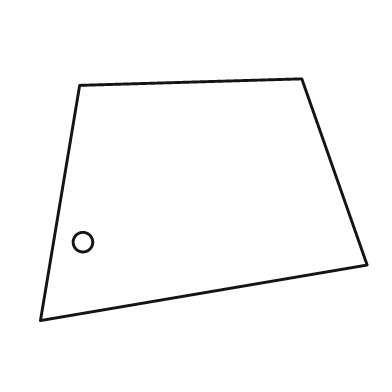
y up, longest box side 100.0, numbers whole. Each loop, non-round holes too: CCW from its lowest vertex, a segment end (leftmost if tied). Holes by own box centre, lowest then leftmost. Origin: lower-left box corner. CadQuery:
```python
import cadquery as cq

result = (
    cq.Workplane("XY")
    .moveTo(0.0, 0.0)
    .lineTo(100.0, 17.0)
    .lineTo(80.0, 74.0)
    .lineTo(12.0, 72.0)
    .close()
    .moveTo(13.0, 24.0)
    .circle(3.0)
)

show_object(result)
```